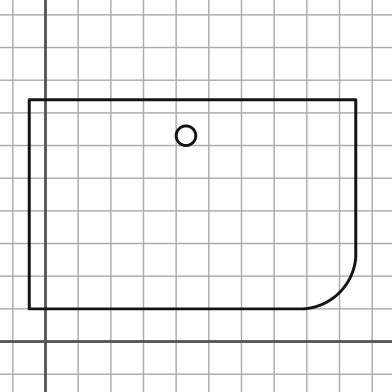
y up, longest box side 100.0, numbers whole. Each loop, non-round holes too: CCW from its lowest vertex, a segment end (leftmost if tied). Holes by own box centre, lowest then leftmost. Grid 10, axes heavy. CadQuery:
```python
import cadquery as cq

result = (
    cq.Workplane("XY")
    .moveTo(-5.0, 10.0)
    .lineTo(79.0, 10.0)
    .threePointArc((90.0, 15.0), (95.0, 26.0))
    .lineTo(95.0, 74.0)
    .lineTo(-5.0, 74.0)
    .close()
    .moveTo(43.0, 63.0)
    .circle(3.0)
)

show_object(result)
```